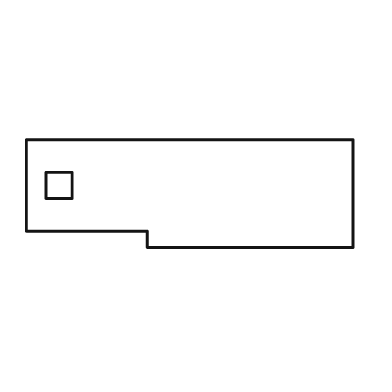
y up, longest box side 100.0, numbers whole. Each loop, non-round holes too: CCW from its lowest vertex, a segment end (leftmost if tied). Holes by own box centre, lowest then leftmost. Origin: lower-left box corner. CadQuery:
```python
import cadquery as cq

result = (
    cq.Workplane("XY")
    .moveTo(37.0, 0.0)
    .lineTo(100.0, 0.0)
    .lineTo(100.0, 33.0)
    .lineTo(0.0, 33.0)
    .lineTo(0.0, 5.0)
    .lineTo(37.0, 5.0)
    .close()
    .moveTo(6.0, 15.0)
    .lineTo(14.0, 15.0)
    .lineTo(14.0, 23.0)
    .lineTo(6.0, 23.0)
    .close()
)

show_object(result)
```